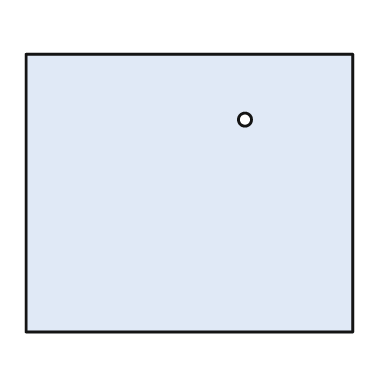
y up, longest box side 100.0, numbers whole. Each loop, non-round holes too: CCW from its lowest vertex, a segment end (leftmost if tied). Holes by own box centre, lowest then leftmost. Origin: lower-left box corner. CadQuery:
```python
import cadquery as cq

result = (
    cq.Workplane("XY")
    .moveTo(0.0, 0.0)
    .lineTo(100.0, 0.0)
    .lineTo(100.0, 85.0)
    .lineTo(0.0, 85.0)
    .close()
    .moveTo(67.0, 65.0)
    .circle(2.0)
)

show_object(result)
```